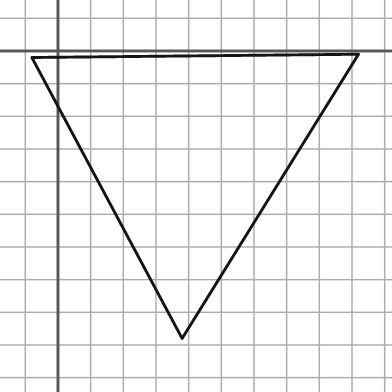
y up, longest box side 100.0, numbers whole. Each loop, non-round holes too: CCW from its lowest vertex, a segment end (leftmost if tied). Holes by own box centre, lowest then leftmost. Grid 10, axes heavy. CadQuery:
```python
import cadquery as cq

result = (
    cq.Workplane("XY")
    .moveTo(38.0, -88.0)
    .lineTo(92.0, -1.0)
    .lineTo(-8.0, -2.0)
    .close()
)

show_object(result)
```